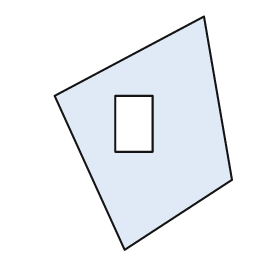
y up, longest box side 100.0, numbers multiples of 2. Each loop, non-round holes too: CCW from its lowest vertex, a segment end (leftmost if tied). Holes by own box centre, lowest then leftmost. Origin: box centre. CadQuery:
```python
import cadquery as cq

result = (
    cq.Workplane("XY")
    .moveTo(-8.0, -50.0)
    .lineTo(38.0, -20.0)
    .lineTo(26.0, 50.0)
    .lineTo(-38.0, 16.0)
    .close()
    .moveTo(-12.0, -8.0)
    .lineTo(4.0, -8.0)
    .lineTo(4.0, 16.0)
    .lineTo(-12.0, 16.0)
    .close()
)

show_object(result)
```